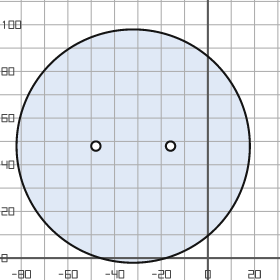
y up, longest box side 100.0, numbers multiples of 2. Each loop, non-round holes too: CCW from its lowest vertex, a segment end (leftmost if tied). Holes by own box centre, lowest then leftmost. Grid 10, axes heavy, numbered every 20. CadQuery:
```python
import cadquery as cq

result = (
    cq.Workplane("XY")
    .moveTo(-32.0, 48.0)
    .circle(50.0)
    .moveTo(-48.0, 48.0)
    .circle(2.0)
    .moveTo(-16.0, 48.0)
    .circle(2.0)
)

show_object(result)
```